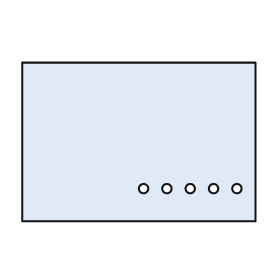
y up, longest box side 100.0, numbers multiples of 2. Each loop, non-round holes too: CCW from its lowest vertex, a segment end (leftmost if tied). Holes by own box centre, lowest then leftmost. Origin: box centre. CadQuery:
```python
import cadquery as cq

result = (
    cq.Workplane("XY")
    .moveTo(-50.0, -34.0)
    .lineTo(50.0, -34.0)
    .lineTo(50.0, 34.0)
    .lineTo(-50.0, 34.0)
    .close()
    .moveTo(2.0, -20.0)
    .circle(2.0)
    .moveTo(12.0, -20.0)
    .circle(2.0)
    .moveTo(22.0, -20.0)
    .circle(2.0)
    .moveTo(32.0, -20.0)
    .circle(2.0)
    .moveTo(42.0, -20.0)
    .circle(2.0)
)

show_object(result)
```